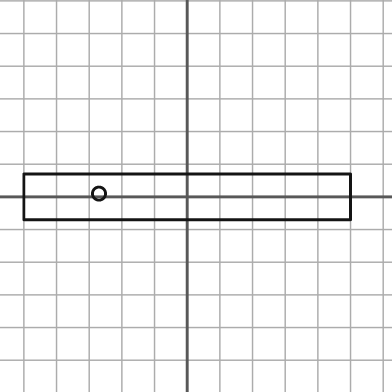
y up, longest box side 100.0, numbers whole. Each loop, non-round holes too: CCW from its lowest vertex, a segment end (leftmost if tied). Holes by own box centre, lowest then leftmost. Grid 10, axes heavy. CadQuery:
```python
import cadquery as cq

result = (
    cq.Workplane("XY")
    .moveTo(-50.0, -7.0)
    .lineTo(50.0, -7.0)
    .lineTo(50.0, 7.0)
    .lineTo(-50.0, 7.0)
    .close()
    .moveTo(-27.0, 1.0)
    .circle(2.0)
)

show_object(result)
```